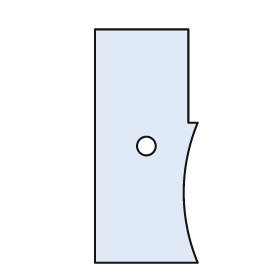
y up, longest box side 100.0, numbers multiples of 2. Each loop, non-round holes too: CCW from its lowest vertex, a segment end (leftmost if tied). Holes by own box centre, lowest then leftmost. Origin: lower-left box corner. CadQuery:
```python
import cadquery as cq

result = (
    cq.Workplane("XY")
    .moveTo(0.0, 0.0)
    .lineTo(44.0, 0.0)
    .threePointArc((38.0, 30.0), (44.0, 60.0))
    .lineTo(40.0, 60.0)
    .lineTo(40.0, 100.0)
    .lineTo(0.0, 100.0)
    .close()
    .moveTo(22.0, 50.0)
    .circle(4.0)
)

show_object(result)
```